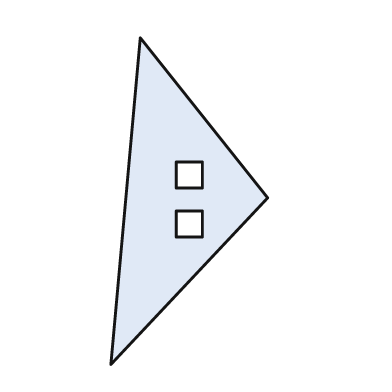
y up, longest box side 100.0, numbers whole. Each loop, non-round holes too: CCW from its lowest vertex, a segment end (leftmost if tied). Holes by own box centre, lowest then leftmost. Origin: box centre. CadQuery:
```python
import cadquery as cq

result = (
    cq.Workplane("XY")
    .moveTo(-24.0, -50.0)
    .lineTo(24.0, 1.0)
    .lineTo(-15.0, 50.0)
    .close()
    .moveTo(-4.0, -11.0)
    .lineTo(4.0, -11.0)
    .lineTo(4.0, -3.0)
    .lineTo(-4.0, -3.0)
    .close()
    .moveTo(-4.0, 4.0)
    .lineTo(4.0, 4.0)
    .lineTo(4.0, 12.0)
    .lineTo(-4.0, 12.0)
    .close()
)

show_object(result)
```